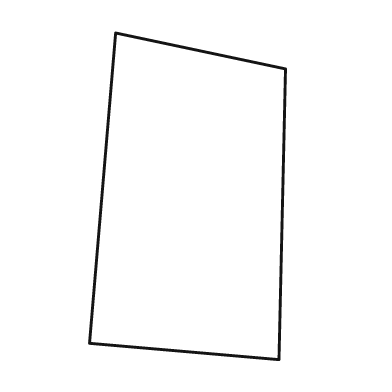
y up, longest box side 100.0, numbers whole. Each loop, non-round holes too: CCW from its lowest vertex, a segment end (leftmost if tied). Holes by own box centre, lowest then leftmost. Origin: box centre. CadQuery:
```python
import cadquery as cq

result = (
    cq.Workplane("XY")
    .moveTo(28.0, -50.0)
    .lineTo(30.0, 39.0)
    .lineTo(-22.0, 50.0)
    .lineTo(-30.0, -45.0)
    .close()
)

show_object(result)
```